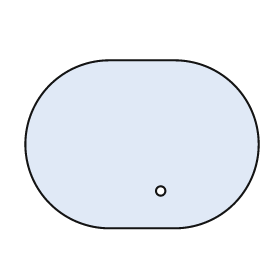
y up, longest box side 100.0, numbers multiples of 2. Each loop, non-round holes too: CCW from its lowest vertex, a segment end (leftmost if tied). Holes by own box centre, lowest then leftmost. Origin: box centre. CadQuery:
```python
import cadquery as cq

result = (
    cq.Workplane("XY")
    .moveTo(-14.0, -36.0)
    .lineTo(14.0, -36.0)
    .threePointArc((50.0, 0.0), (14.0, 36.0))
    .lineTo(-14.0, 36.0)
    .threePointArc((-50.0, 0.0), (-14.0, -36.0))
    .close()
    .moveTo(8.0, -20.0)
    .circle(2.0)
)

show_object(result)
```